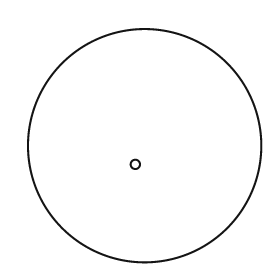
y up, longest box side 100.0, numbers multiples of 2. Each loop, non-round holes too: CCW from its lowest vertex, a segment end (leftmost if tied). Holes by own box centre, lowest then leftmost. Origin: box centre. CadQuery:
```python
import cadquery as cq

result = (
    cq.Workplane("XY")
    .moveTo(0.0, 0.0)
    .circle(50.0)
    .moveTo(-4.0, -8.0)
    .circle(2.0)
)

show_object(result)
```